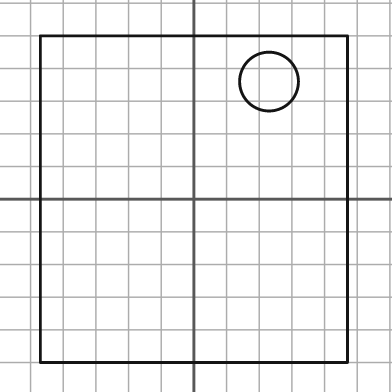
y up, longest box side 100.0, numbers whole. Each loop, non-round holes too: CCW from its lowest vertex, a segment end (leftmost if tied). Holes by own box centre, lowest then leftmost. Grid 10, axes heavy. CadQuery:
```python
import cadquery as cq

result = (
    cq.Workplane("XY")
    .moveTo(-47.0, -50.0)
    .lineTo(47.0, -50.0)
    .lineTo(47.0, 50.0)
    .lineTo(-47.0, 50.0)
    .close()
    .moveTo(23.0, 36.0)
    .circle(9.0)
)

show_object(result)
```